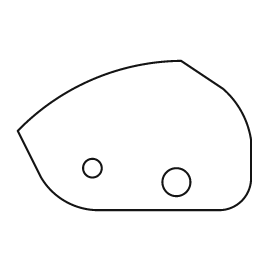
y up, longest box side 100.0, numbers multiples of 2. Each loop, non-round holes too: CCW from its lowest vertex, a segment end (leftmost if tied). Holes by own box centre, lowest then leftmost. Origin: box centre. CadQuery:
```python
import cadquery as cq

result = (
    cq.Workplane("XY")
    .moveTo(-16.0, -32.0)
    .lineTo(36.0, -32.0)
    .threePointArc((46.0, -28.0), (50.0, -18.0))
    .lineTo(50.0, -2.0)
    .threePointArc((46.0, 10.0), (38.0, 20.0))
    .lineTo(20.0, 32.0)
    .threePointArc((-18.0, 24.0), (-50.0, 2.0))
    .lineTo(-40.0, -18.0)
    .threePointArc((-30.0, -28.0), (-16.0, -32.0))
    .close()
    .moveTo(18.0, -20.0)
    .circle(6.0)
    .moveTo(-18.0, -14.0)
    .circle(4.0)
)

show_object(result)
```